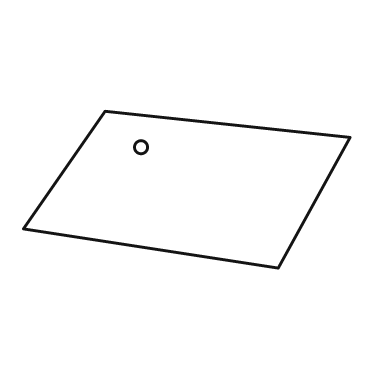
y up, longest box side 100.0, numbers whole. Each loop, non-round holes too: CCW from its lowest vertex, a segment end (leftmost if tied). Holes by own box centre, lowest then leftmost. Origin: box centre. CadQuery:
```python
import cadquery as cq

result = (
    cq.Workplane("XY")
    .moveTo(28.0, -24.0)
    .lineTo(50.0, 16.0)
    .lineTo(-25.0, 24.0)
    .lineTo(-50.0, -12.0)
    .close()
    .moveTo(-14.0, 13.0)
    .circle(2.0)
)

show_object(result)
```